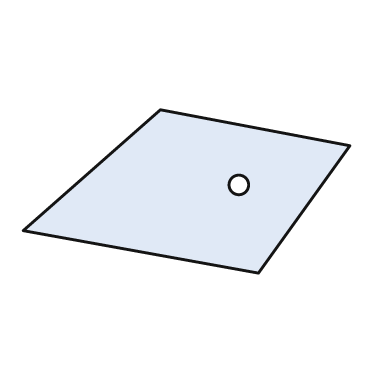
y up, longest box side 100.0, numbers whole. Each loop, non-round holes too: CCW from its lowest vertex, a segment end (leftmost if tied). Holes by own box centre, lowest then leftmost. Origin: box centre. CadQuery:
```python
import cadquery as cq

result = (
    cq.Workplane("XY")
    .moveTo(22.0, -25.0)
    .lineTo(50.0, 14.0)
    .lineTo(-8.0, 25.0)
    .lineTo(-50.0, -12.0)
    .close()
    .moveTo(16.0, 2.0)
    .circle(3.0)
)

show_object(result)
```